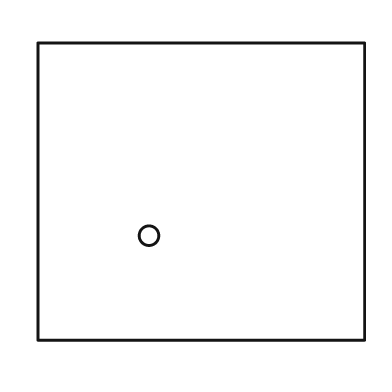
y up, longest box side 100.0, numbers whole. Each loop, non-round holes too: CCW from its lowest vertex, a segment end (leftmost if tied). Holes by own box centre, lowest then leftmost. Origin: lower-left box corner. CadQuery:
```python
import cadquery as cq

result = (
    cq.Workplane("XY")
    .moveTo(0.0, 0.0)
    .lineTo(100.0, 0.0)
    .lineTo(100.0, 91.0)
    .lineTo(0.0, 91.0)
    .close()
    .moveTo(34.0, 32.0)
    .circle(3.0)
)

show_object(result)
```